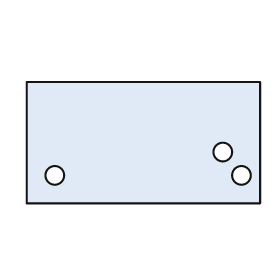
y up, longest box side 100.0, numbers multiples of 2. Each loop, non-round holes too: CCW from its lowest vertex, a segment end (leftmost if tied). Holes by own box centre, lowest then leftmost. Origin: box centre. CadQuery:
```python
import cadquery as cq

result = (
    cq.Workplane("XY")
    .moveTo(-50.0, -26.0)
    .lineTo(50.0, -26.0)
    .lineTo(50.0, 26.0)
    .lineTo(-50.0, 26.0)
    .close()
    .moveTo(-38.0, -14.0)
    .circle(4.0)
    .moveTo(42.0, -14.0)
    .circle(4.0)
    .moveTo(34.0, -4.0)
    .circle(4.0)
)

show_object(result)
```